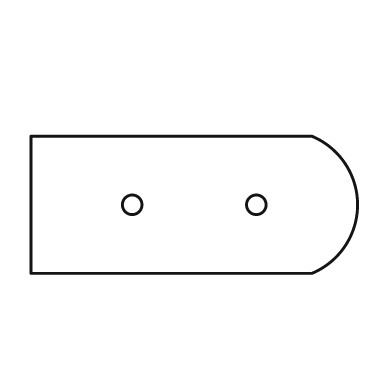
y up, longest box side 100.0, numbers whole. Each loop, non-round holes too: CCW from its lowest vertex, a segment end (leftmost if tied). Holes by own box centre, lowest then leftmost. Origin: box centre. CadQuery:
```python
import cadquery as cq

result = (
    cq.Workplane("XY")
    .moveTo(-50.0, -21.0)
    .lineTo(36.0, -21.0)
    .threePointArc((50.0, 0.0), (36.0, 21.0))
    .lineTo(-50.0, 21.0)
    .close()
    .moveTo(-19.0, 0.0)
    .circle(3.0)
    .moveTo(19.0, 0.0)
    .circle(3.0)
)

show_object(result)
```